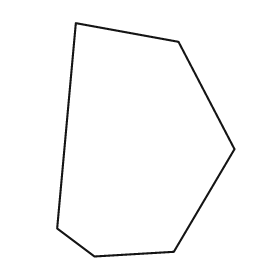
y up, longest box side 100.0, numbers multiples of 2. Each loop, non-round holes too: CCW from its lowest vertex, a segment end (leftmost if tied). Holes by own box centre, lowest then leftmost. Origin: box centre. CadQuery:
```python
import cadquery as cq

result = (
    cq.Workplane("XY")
    .moveTo(-22.0, -50.0)
    .lineTo(12.0, -48.0)
    .lineTo(38.0, -4.0)
    .lineTo(14.0, 42.0)
    .lineTo(-30.0, 50.0)
    .lineTo(-38.0, -38.0)
    .close()
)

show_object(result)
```